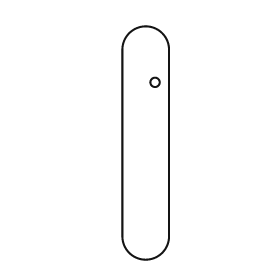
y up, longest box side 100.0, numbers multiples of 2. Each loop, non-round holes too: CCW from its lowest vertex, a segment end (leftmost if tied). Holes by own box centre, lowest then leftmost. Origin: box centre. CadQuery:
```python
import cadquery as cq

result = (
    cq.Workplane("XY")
    .moveTo(-10.0, -40.0)
    .threePointArc((0.0, -50.0), (10.0, -40.0))
    .lineTo(10.0, 40.0)
    .threePointArc((0.0, 50.0), (-10.0, 40.0))
    .close()
    .moveTo(4.0, 26.0)
    .circle(2.0)
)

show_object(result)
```